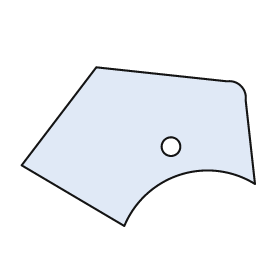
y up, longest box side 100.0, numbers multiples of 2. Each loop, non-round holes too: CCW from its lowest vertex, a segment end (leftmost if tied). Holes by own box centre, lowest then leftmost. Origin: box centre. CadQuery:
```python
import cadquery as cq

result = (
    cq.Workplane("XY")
    .moveTo(-6.0, -34.0)
    .threePointArc((18.0, -12.0), (50.0, -16.0))
    .lineTo(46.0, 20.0)
    .threePointArc((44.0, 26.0), (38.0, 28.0))
    .lineTo(-18.0, 34.0)
    .lineTo(-50.0, -8.0)
    .close()
    .moveTo(14.0, 0.0)
    .circle(4.0)
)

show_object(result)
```